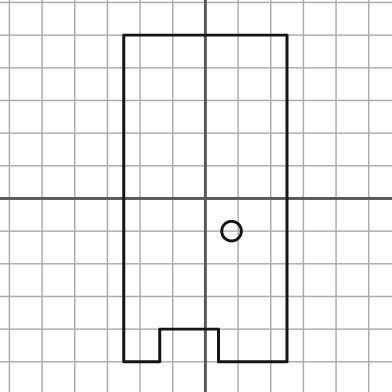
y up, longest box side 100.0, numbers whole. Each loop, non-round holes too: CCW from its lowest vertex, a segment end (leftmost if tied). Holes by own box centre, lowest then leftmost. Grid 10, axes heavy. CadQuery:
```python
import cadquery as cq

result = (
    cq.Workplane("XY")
    .moveTo(-25.0, -50.0)
    .lineTo(-14.0, -50.0)
    .lineTo(-14.0, -40.0)
    .lineTo(4.0, -40.0)
    .lineTo(4.0, -50.0)
    .lineTo(25.0, -50.0)
    .lineTo(25.0, 50.0)
    .lineTo(-25.0, 50.0)
    .close()
    .moveTo(8.0, -10.0)
    .circle(3.0)
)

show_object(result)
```